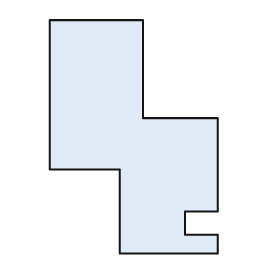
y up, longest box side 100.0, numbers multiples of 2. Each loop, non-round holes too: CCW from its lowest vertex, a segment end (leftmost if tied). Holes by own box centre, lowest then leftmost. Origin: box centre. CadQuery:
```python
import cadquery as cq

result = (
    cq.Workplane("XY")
    .moveTo(-6.0, -50.0)
    .lineTo(36.0, -50.0)
    .lineTo(36.0, -42.0)
    .lineTo(22.0, -42.0)
    .lineTo(22.0, -32.0)
    .lineTo(36.0, -32.0)
    .lineTo(36.0, 8.0)
    .lineTo(4.0, 8.0)
    .lineTo(4.0, 50.0)
    .lineTo(-36.0, 50.0)
    .lineTo(-36.0, -14.0)
    .lineTo(-6.0, -14.0)
    .close()
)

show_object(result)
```